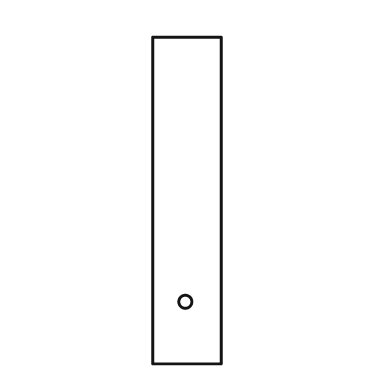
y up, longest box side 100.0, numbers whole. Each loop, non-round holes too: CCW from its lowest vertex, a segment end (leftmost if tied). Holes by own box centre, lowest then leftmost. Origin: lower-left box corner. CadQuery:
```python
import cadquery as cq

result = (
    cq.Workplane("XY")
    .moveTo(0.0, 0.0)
    .lineTo(21.0, 0.0)
    .lineTo(21.0, 100.0)
    .lineTo(0.0, 100.0)
    .close()
    .moveTo(10.0, 19.0)
    .circle(2.0)
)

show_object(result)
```